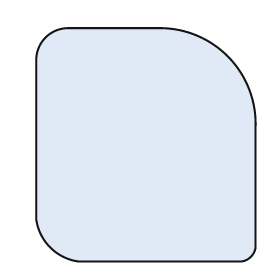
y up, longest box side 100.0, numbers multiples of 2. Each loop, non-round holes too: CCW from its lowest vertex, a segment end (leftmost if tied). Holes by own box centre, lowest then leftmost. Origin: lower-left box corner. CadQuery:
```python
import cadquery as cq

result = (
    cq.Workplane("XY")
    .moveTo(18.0, 0.0)
    .lineTo(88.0, 0.0)
    .threePointArc((92.0, 2.0), (94.0, 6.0))
    .lineTo(94.0, 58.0)
    .threePointArc((82.0, 88.0), (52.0, 100.0))
    .lineTo(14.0, 100.0)
    .threePointArc((4.0, 96.0), (0.0, 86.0))
    .lineTo(0.0, 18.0)
    .threePointArc((6.0, 6.0), (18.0, 0.0))
    .close()
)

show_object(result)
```